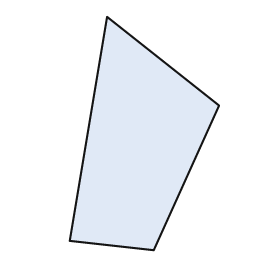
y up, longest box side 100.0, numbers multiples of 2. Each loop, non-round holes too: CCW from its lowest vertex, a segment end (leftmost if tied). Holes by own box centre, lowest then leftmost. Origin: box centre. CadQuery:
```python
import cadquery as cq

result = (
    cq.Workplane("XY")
    .moveTo(4.0, -50.0)
    .lineTo(32.0, 12.0)
    .lineTo(-16.0, 50.0)
    .lineTo(-32.0, -46.0)
    .close()
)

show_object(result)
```